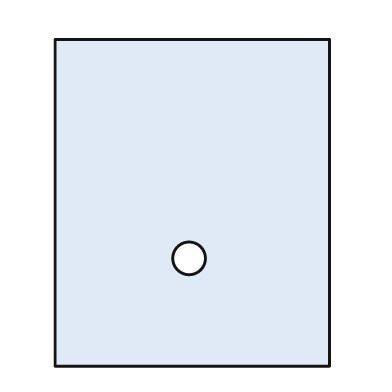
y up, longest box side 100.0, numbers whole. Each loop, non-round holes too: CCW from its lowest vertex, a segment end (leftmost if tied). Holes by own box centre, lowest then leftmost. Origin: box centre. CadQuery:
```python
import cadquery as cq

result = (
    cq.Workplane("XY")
    .moveTo(-42.0, -50.0)
    .lineTo(42.0, -50.0)
    .lineTo(42.0, 50.0)
    .lineTo(-42.0, 50.0)
    .close()
    .moveTo(-1.0, -17.0)
    .circle(5.0)
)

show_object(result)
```